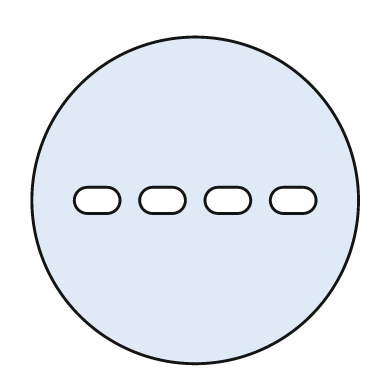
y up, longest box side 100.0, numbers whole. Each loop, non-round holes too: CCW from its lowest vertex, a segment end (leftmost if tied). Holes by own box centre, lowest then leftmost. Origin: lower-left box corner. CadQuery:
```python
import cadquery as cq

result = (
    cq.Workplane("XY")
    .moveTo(50.0, 50.0)
    .circle(50.0)
    .moveTo(17.0, 46.0)
    .lineTo(23.0, 46.0)
    .threePointArc((27.0, 50.0), (23.0, 54.0))
    .lineTo(17.0, 54.0)
    .threePointArc((13.0, 50.0), (17.0, 46.0))
    .close()
    .moveTo(37.0, 46.0)
    .lineTo(43.0, 46.0)
    .threePointArc((47.0, 50.0), (43.0, 54.0))
    .lineTo(37.0, 54.0)
    .threePointArc((33.0, 50.0), (37.0, 46.0))
    .close()
    .moveTo(57.0, 46.0)
    .lineTo(63.0, 46.0)
    .threePointArc((67.0, 50.0), (63.0, 54.0))
    .lineTo(57.0, 54.0)
    .threePointArc((53.0, 50.0), (57.0, 46.0))
    .close()
    .moveTo(77.0, 46.0)
    .lineTo(83.0, 46.0)
    .threePointArc((87.0, 50.0), (83.0, 54.0))
    .lineTo(77.0, 54.0)
    .threePointArc((73.0, 50.0), (77.0, 46.0))
    .close()
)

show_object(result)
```